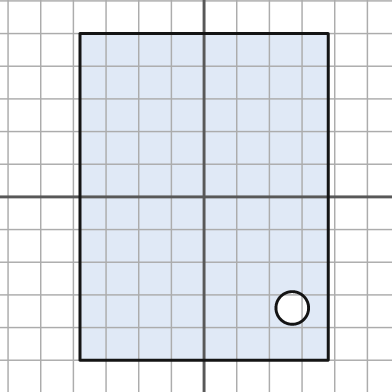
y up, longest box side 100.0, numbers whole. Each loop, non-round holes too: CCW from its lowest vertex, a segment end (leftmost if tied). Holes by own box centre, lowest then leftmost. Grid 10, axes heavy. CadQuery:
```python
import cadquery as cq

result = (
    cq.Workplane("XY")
    .moveTo(-38.0, -50.0)
    .lineTo(38.0, -50.0)
    .lineTo(38.0, 50.0)
    .lineTo(-38.0, 50.0)
    .close()
    .moveTo(27.0, -34.0)
    .circle(5.0)
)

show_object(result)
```